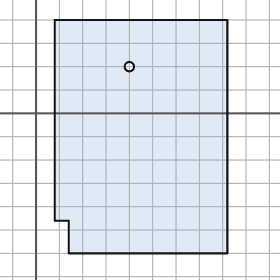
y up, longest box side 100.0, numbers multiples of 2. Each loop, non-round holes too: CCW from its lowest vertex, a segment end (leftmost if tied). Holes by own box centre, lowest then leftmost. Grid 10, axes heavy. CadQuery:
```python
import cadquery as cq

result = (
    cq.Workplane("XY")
    .moveTo(14.0, -60.0)
    .lineTo(82.0, -60.0)
    .lineTo(82.0, 40.0)
    .lineTo(8.0, 40.0)
    .lineTo(8.0, -46.0)
    .lineTo(14.0, -46.0)
    .close()
    .moveTo(40.0, 20.0)
    .circle(2.0)
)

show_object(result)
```